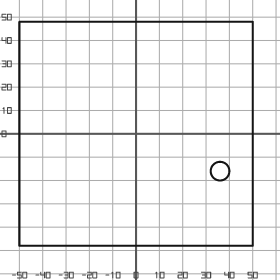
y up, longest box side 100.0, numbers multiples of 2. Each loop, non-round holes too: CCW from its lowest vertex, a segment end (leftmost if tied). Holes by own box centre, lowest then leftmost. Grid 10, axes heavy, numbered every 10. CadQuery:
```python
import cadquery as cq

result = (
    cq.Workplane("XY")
    .moveTo(-50.0, -48.0)
    .lineTo(50.0, -48.0)
    .lineTo(50.0, 48.0)
    .lineTo(-50.0, 48.0)
    .close()
    .moveTo(36.0, -16.0)
    .circle(4.0)
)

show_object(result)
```